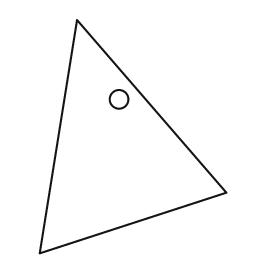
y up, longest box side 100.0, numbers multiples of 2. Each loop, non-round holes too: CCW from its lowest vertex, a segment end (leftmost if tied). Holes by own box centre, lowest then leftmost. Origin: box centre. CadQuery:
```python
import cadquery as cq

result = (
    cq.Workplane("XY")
    .moveTo(-40.0, -50.0)
    .lineTo(40.0, -24.0)
    .lineTo(-24.0, 50.0)
    .close()
    .moveTo(-6.0, 16.0)
    .circle(4.0)
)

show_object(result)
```